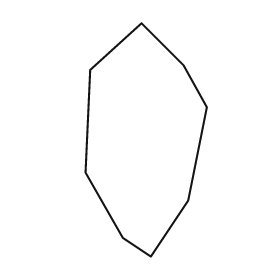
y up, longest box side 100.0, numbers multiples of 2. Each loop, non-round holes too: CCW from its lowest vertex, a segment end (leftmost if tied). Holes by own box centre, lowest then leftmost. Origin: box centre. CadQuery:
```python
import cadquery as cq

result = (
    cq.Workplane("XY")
    .moveTo(2.0, -50.0)
    .lineTo(18.0, -26.0)
    .lineTo(26.0, 14.0)
    .lineTo(16.0, 32.0)
    .lineTo(-2.0, 50.0)
    .lineTo(-24.0, 30.0)
    .lineTo(-26.0, -14.0)
    .lineTo(-10.0, -42.0)
    .close()
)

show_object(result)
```